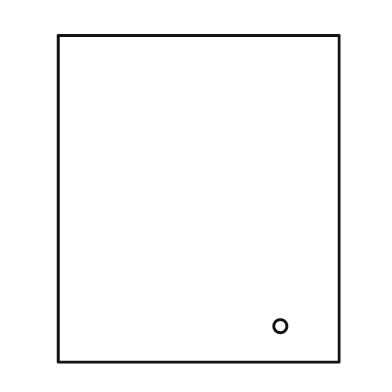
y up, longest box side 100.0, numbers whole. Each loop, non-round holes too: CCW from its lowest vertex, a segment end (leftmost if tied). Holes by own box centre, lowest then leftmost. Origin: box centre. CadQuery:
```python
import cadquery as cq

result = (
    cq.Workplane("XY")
    .moveTo(-43.0, -50.0)
    .lineTo(43.0, -50.0)
    .lineTo(43.0, 50.0)
    .lineTo(-43.0, 50.0)
    .close()
    .moveTo(25.0, -39.0)
    .circle(2.0)
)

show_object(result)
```